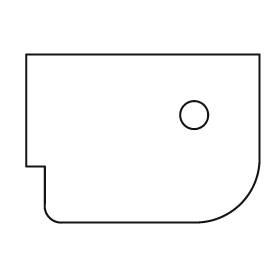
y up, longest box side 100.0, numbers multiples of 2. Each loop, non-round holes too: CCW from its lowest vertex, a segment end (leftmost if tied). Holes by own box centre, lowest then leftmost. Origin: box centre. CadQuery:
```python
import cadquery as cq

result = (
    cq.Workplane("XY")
    .moveTo(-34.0, -36.0)
    .lineTo(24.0, -36.0)
    .threePointArc((42.0, -28.0), (50.0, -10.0))
    .lineTo(50.0, 36.0)
    .lineTo(-50.0, 36.0)
    .lineTo(-50.0, -12.0)
    .lineTo(-42.0, -12.0)
    .lineTo(-42.0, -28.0)
    .threePointArc((-40.0, -34.0), (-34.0, -36.0))
    .close()
    .moveTo(22.0, 10.0)
    .circle(6.0)
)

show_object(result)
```